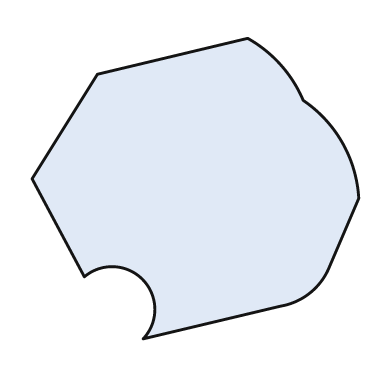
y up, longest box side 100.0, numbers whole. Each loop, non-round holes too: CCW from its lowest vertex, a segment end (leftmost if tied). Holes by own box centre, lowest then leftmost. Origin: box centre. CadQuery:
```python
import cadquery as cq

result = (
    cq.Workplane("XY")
    .moveTo(-16.0, -46.0)
    .lineTo(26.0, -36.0)
    .threePointArc((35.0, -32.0), (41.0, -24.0))
    .lineTo(50.0, -3.0)
    .threePointArc((45.0, 14.0), (33.0, 27.0))
    .threePointArc((26.0, 38.0), (16.0, 46.0))
    .lineTo(-30.0, 35.0)
    .lineTo(-50.0, 3.0)
    .lineTo(-34.0, -27.0)
    .threePointArc((-16.0, -28.0), (-16.0, -46.0))
    .close()
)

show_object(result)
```